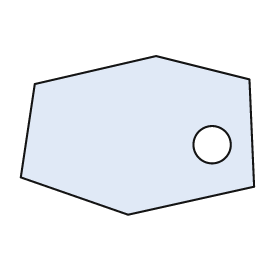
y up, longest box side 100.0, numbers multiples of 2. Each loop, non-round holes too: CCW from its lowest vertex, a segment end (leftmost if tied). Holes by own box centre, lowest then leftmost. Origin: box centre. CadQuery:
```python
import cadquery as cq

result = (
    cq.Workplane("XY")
    .moveTo(-4.0, -34.0)
    .lineTo(50.0, -22.0)
    .lineTo(48.0, 24.0)
    .lineTo(8.0, 34.0)
    .lineTo(-44.0, 22.0)
    .lineTo(-50.0, -18.0)
    .close()
    .moveTo(32.0, -4.0)
    .circle(8.0)
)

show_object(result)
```